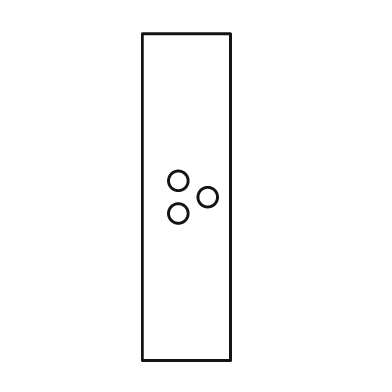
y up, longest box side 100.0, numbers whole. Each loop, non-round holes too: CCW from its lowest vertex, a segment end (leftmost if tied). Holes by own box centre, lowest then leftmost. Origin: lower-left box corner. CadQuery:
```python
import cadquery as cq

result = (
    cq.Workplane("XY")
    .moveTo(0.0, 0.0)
    .lineTo(27.0, 0.0)
    .lineTo(27.0, 100.0)
    .lineTo(0.0, 100.0)
    .close()
    .moveTo(11.0, 45.0)
    .circle(3.0)
    .moveTo(20.0, 50.0)
    .circle(3.0)
    .moveTo(11.0, 55.0)
    .circle(3.0)
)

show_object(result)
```